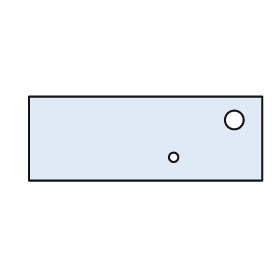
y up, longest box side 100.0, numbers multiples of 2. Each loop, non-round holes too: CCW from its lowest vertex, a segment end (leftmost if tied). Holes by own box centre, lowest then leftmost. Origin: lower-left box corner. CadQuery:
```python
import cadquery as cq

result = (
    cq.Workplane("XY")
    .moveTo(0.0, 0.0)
    .lineTo(100.0, 0.0)
    .lineTo(100.0, 36.0)
    .lineTo(0.0, 36.0)
    .close()
    .moveTo(62.0, 10.0)
    .circle(2.0)
    .moveTo(88.0, 26.0)
    .circle(4.0)
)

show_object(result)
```